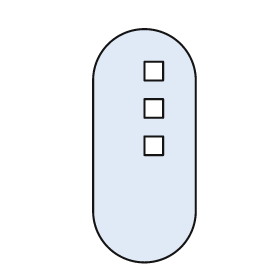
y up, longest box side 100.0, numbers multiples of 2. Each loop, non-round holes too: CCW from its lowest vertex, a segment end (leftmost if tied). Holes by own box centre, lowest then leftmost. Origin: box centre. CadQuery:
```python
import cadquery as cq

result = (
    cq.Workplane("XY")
    .moveTo(-22.0, -28.0)
    .threePointArc((0.0, -50.0), (22.0, -28.0))
    .lineTo(22.0, 28.0)
    .threePointArc((0.0, 50.0), (-22.0, 28.0))
    .close()
    .moveTo(0.0, -4.0)
    .lineTo(8.0, -4.0)
    .lineTo(8.0, 4.0)
    .lineTo(0.0, 4.0)
    .close()
    .moveTo(0.0, 12.0)
    .lineTo(8.0, 12.0)
    .lineTo(8.0, 20.0)
    .lineTo(0.0, 20.0)
    .close()
    .moveTo(0.0, 28.0)
    .lineTo(8.0, 28.0)
    .lineTo(8.0, 36.0)
    .lineTo(0.0, 36.0)
    .close()
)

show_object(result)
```